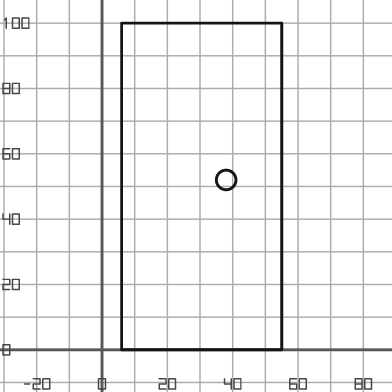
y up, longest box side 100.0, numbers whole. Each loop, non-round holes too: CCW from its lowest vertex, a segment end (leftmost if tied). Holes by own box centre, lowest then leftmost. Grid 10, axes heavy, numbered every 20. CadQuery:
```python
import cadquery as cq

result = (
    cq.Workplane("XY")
    .moveTo(6.0, 0.0)
    .lineTo(55.0, 0.0)
    .lineTo(55.0, 100.0)
    .lineTo(6.0, 100.0)
    .close()
    .moveTo(38.0, 52.0)
    .circle(3.0)
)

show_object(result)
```